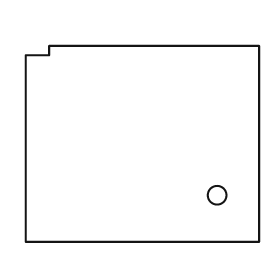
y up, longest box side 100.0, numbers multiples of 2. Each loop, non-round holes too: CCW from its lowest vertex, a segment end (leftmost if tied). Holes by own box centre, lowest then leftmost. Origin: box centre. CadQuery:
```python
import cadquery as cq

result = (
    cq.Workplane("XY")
    .moveTo(-50.0, -42.0)
    .lineTo(50.0, -42.0)
    .lineTo(50.0, 42.0)
    .lineTo(-40.0, 42.0)
    .lineTo(-40.0, 38.0)
    .lineTo(-50.0, 38.0)
    .close()
    .moveTo(32.0, -22.0)
    .circle(4.0)
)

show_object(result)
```